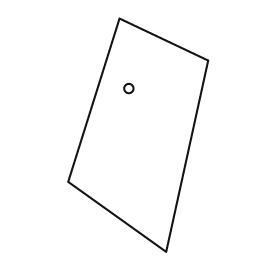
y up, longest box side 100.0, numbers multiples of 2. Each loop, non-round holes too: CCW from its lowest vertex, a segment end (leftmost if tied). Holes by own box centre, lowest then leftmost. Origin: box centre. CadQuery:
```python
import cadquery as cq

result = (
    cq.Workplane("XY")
    .moveTo(12.0, -50.0)
    .lineTo(30.0, 32.0)
    .lineTo(-8.0, 50.0)
    .lineTo(-30.0, -20.0)
    .close()
    .moveTo(-4.0, 20.0)
    .circle(2.0)
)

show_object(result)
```